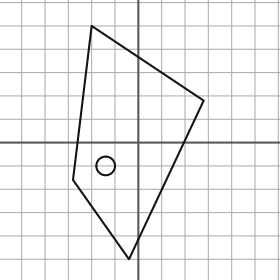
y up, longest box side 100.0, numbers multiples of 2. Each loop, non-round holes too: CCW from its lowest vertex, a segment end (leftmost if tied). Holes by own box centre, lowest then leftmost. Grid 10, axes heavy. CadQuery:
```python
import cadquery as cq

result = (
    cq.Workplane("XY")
    .moveTo(-4.0, -50.0)
    .lineTo(28.0, 18.0)
    .lineTo(-20.0, 50.0)
    .lineTo(-28.0, -16.0)
    .close()
    .moveTo(-14.0, -10.0)
    .circle(4.0)
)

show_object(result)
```